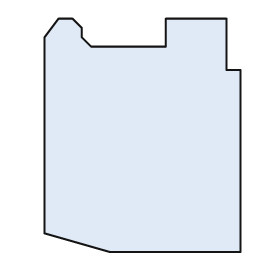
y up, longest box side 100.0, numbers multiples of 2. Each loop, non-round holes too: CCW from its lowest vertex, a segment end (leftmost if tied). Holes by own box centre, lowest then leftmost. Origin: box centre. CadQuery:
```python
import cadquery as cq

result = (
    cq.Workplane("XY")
    .moveTo(-14.0, -50.0)
    .lineTo(42.0, -50.0)
    .lineTo(42.0, 28.0)
    .lineTo(36.0, 28.0)
    .lineTo(36.0, 50.0)
    .lineTo(10.0, 50.0)
    .lineTo(10.0, 38.0)
    .lineTo(-22.0, 38.0)
    .lineTo(-26.0, 42.0)
    .lineTo(-26.0, 46.0)
    .lineTo(-30.0, 50.0)
    .lineTo(-36.0, 50.0)
    .lineTo(-42.0, 42.0)
    .lineTo(-42.0, -42.0)
    .close()
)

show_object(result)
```